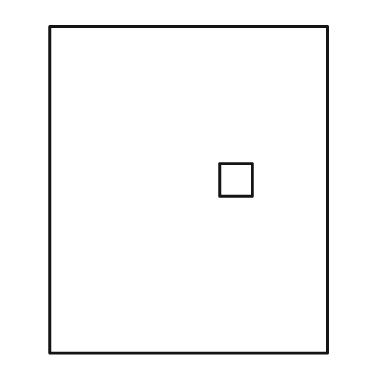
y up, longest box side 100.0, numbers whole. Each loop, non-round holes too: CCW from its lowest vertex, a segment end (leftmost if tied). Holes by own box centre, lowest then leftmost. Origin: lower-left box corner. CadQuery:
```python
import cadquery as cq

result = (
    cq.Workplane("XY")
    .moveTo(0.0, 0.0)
    .lineTo(85.0, 0.0)
    .lineTo(85.0, 100.0)
    .lineTo(0.0, 100.0)
    .close()
    .moveTo(52.0, 48.0)
    .lineTo(62.0, 48.0)
    .lineTo(62.0, 58.0)
    .lineTo(52.0, 58.0)
    .close()
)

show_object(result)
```